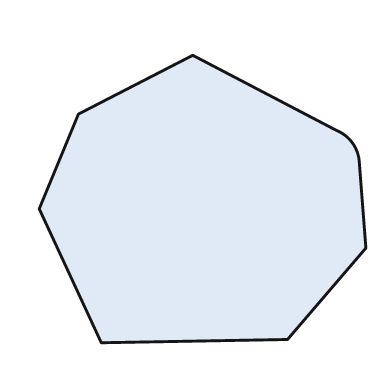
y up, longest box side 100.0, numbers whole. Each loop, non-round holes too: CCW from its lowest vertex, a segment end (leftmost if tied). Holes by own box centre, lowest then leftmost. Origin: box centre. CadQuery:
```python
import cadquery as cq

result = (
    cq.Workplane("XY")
    .moveTo(-31.0, -44.0)
    .lineTo(26.0, -43.0)
    .lineTo(50.0, -15.0)
    .lineTo(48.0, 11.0)
    .threePointArc((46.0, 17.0), (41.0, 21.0))
    .lineTo(-3.0, 44.0)
    .lineTo(-38.0, 26.0)
    .lineTo(-50.0, -3.0)
    .close()
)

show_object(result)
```